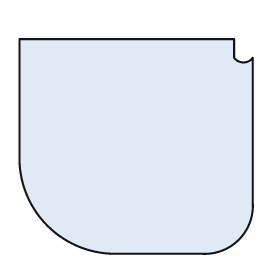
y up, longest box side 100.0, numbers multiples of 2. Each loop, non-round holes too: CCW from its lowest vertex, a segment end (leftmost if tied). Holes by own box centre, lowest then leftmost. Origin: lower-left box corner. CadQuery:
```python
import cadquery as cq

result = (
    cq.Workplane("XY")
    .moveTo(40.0, 0.0)
    .lineTo(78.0, 0.0)
    .threePointArc((94.0, 6.0), (100.0, 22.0))
    .lineTo(100.0, 84.0)
    .threePointArc((96.0, 82.0), (92.0, 84.0))
    .lineTo(92.0, 92.0)
    .lineTo(0.0, 92.0)
    .lineTo(0.0, 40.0)
    .threePointArc((12.0, 12.0), (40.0, 0.0))
    .close()
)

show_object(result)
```